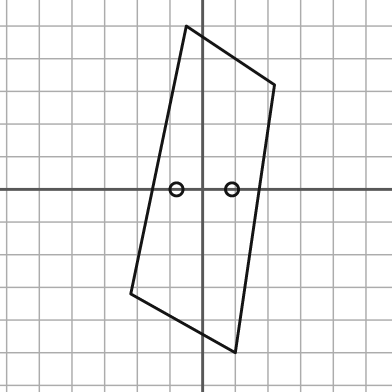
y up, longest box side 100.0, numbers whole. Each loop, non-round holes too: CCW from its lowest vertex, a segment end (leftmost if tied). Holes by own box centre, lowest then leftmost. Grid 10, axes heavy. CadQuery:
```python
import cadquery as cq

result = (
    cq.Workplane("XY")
    .moveTo(10.0, -50.0)
    .lineTo(22.0, 32.0)
    .lineTo(-5.0, 50.0)
    .lineTo(-22.0, -32.0)
    .close()
    .moveTo(-8.0, 0.0)
    .circle(2.0)
    .moveTo(9.0, 0.0)
    .circle(2.0)
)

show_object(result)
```